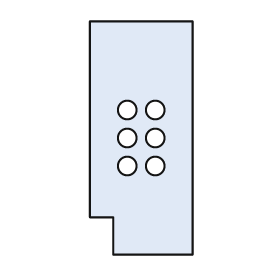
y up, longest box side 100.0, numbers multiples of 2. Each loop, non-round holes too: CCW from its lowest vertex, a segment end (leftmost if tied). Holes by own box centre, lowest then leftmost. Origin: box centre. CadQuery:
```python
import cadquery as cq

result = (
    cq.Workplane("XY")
    .moveTo(-12.0, -50.0)
    .lineTo(22.0, -50.0)
    .lineTo(22.0, 50.0)
    .lineTo(-22.0, 50.0)
    .lineTo(-22.0, -34.0)
    .lineTo(-12.0, -34.0)
    .close()
    .moveTo(-6.0, -12.0)
    .circle(4.0)
    .moveTo(6.0, -12.0)
    .circle(4.0)
    .moveTo(-6.0, 0.0)
    .circle(4.0)
    .moveTo(6.0, 0.0)
    .circle(4.0)
    .moveTo(-6.0, 12.0)
    .circle(4.0)
    .moveTo(6.0, 12.0)
    .circle(4.0)
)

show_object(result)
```